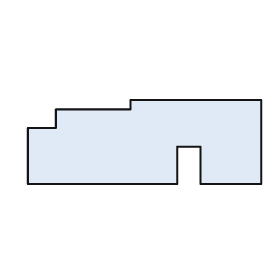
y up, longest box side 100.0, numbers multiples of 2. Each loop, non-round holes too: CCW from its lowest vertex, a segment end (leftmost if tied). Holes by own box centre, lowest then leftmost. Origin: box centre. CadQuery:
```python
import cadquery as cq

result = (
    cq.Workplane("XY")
    .moveTo(-50.0, -18.0)
    .lineTo(14.0, -18.0)
    .lineTo(14.0, -2.0)
    .lineTo(24.0, -2.0)
    .lineTo(24.0, -18.0)
    .lineTo(50.0, -18.0)
    .lineTo(50.0, 18.0)
    .lineTo(-6.0, 18.0)
    .lineTo(-6.0, 14.0)
    .lineTo(-38.0, 14.0)
    .lineTo(-38.0, 6.0)
    .lineTo(-50.0, 6.0)
    .close()
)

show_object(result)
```